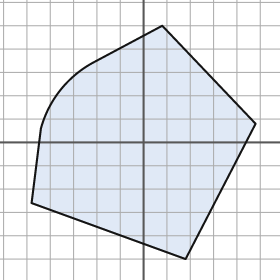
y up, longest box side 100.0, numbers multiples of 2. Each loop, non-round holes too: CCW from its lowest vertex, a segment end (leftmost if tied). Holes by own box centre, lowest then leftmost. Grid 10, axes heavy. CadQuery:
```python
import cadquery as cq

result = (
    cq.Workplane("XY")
    .moveTo(18.0, -50.0)
    .lineTo(48.0, 8.0)
    .lineTo(8.0, 50.0)
    .lineTo(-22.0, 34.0)
    .threePointArc((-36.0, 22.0), (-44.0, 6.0))
    .lineTo(-48.0, -26.0)
    .close()
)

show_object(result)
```